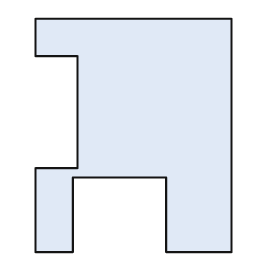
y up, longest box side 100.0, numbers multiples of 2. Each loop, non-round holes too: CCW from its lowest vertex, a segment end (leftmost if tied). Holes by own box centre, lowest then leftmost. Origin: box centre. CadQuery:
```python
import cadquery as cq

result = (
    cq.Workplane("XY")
    .moveTo(-42.0, -50.0)
    .lineTo(-26.0, -50.0)
    .lineTo(-26.0, -18.0)
    .lineTo(14.0, -18.0)
    .lineTo(14.0, -50.0)
    .lineTo(42.0, -50.0)
    .lineTo(42.0, 50.0)
    .lineTo(-42.0, 50.0)
    .lineTo(-42.0, 34.0)
    .lineTo(-24.0, 34.0)
    .lineTo(-24.0, -14.0)
    .lineTo(-42.0, -14.0)
    .close()
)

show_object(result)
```